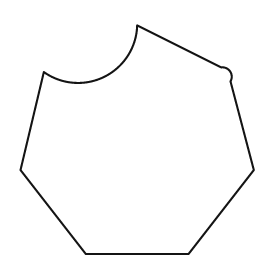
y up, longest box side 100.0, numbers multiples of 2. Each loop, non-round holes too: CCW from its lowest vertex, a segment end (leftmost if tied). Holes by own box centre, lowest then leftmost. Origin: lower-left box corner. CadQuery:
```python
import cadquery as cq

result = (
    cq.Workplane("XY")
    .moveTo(28.0, 0.0)
    .lineTo(72.0, 0.0)
    .lineTo(100.0, 36.0)
    .lineTo(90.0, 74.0)
    .threePointArc((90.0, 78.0), (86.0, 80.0))
    .lineTo(50.0, 98.0)
    .threePointArc((36.0, 76.0), (10.0, 78.0))
    .lineTo(0.0, 36.0)
    .close()
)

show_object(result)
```